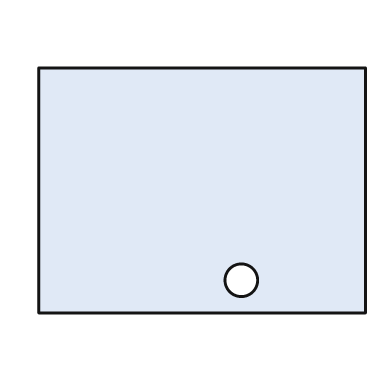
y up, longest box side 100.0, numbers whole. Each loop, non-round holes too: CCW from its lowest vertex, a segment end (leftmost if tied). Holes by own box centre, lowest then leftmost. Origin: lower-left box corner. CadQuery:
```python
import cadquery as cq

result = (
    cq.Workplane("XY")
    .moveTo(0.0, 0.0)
    .lineTo(100.0, 0.0)
    .lineTo(100.0, 75.0)
    .lineTo(0.0, 75.0)
    .close()
    .moveTo(62.0, 10.0)
    .circle(5.0)
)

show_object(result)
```